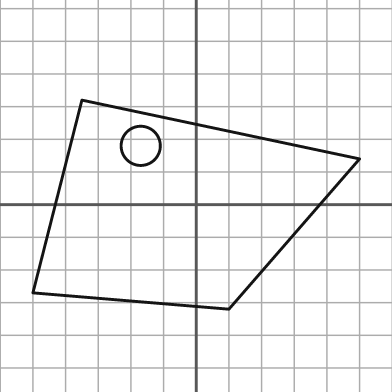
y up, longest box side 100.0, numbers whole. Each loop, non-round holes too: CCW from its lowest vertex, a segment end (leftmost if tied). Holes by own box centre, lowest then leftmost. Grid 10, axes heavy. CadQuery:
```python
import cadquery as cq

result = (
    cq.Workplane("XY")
    .moveTo(10.0, -32.0)
    .lineTo(50.0, 14.0)
    .lineTo(-35.0, 32.0)
    .lineTo(-50.0, -27.0)
    .close()
    .moveTo(-17.0, 18.0)
    .circle(6.0)
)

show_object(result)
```